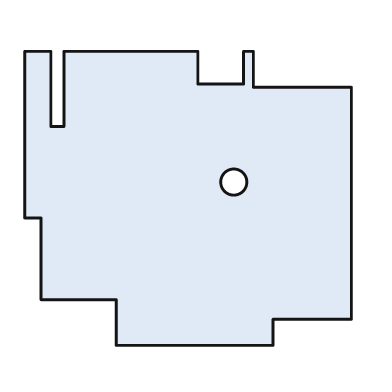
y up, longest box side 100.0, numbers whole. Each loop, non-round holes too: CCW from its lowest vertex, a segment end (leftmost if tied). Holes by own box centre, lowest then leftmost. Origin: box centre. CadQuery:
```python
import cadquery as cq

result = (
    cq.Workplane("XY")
    .moveTo(-22.0, -45.0)
    .lineTo(26.0, -45.0)
    .lineTo(26.0, -37.0)
    .lineTo(50.0, -37.0)
    .lineTo(50.0, 34.0)
    .lineTo(20.0, 34.0)
    .lineTo(20.0, 45.0)
    .lineTo(17.0, 45.0)
    .lineTo(17.0, 35.0)
    .lineTo(3.0, 35.0)
    .lineTo(3.0, 45.0)
    .lineTo(-38.0, 45.0)
    .lineTo(-38.0, 22.0)
    .lineTo(-42.0, 22.0)
    .lineTo(-42.0, 45.0)
    .lineTo(-50.0, 45.0)
    .lineTo(-50.0, -6.0)
    .lineTo(-45.0, -6.0)
    .lineTo(-45.0, -31.0)
    .lineTo(-22.0, -31.0)
    .close()
    .moveTo(14.0, 5.0)
    .circle(4.0)
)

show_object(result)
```